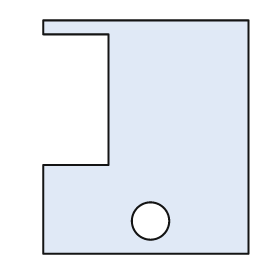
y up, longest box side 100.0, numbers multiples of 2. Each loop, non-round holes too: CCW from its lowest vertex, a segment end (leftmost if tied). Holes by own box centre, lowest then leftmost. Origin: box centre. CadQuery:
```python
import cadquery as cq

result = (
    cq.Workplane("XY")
    .moveTo(-44.0, -50.0)
    .lineTo(44.0, -50.0)
    .lineTo(44.0, 50.0)
    .lineTo(-44.0, 50.0)
    .lineTo(-44.0, 44.0)
    .lineTo(-16.0, 44.0)
    .lineTo(-16.0, -12.0)
    .lineTo(-44.0, -12.0)
    .close()
    .moveTo(2.0, -36.0)
    .circle(8.0)
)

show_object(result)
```